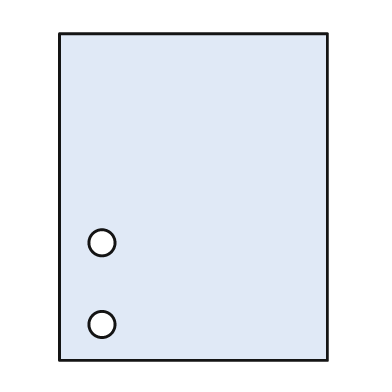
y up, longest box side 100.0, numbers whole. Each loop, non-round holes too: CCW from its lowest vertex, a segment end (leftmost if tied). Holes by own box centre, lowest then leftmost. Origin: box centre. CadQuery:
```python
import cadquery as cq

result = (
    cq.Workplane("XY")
    .moveTo(-41.0, -50.0)
    .lineTo(41.0, -50.0)
    .lineTo(41.0, 50.0)
    .lineTo(-41.0, 50.0)
    .close()
    .moveTo(-28.0, -39.0)
    .circle(4.0)
    .moveTo(-28.0, -14.0)
    .circle(4.0)
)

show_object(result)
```